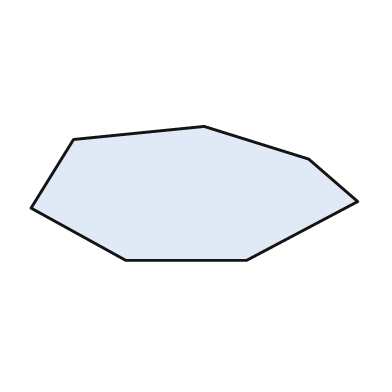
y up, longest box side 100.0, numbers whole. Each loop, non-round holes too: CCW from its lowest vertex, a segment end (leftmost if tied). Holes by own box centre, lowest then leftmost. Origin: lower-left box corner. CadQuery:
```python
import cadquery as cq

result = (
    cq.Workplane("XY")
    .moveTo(29.0, 0.0)
    .lineTo(66.0, 0.0)
    .lineTo(100.0, 18.0)
    .lineTo(85.0, 31.0)
    .lineTo(53.0, 41.0)
    .lineTo(13.0, 37.0)
    .lineTo(0.0, 16.0)
    .close()
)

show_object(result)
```